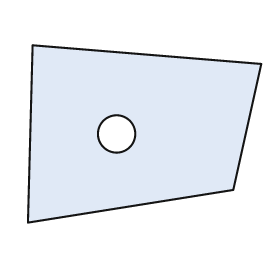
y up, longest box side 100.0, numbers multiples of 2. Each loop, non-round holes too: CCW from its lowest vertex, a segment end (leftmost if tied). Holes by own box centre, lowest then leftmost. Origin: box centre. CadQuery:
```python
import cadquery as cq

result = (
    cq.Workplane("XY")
    .moveTo(-50.0, -38.0)
    .lineTo(38.0, -24.0)
    .lineTo(50.0, 30.0)
    .lineTo(-48.0, 38.0)
    .close()
    .moveTo(-12.0, 0.0)
    .circle(8.0)
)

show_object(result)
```